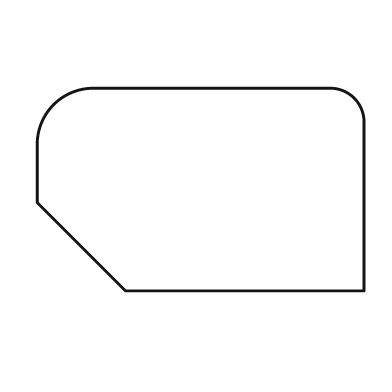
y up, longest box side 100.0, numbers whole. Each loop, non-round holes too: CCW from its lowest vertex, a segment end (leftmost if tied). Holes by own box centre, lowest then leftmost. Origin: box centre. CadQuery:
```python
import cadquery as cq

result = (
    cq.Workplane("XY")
    .moveTo(-23.0, -31.0)
    .lineTo(50.0, -31.0)
    .lineTo(50.0, 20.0)
    .threePointArc((47.0, 28.0), (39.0, 31.0))
    .lineTo(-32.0, 31.0)
    .threePointArc((-45.0, 26.0), (-50.0, 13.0))
    .lineTo(-50.0, -4.0)
    .close()
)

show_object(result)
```